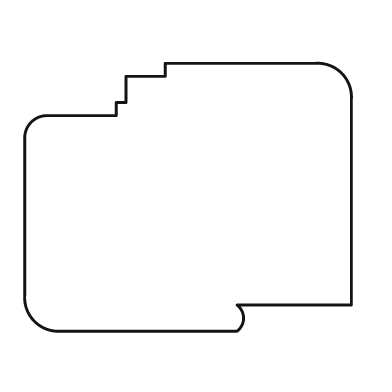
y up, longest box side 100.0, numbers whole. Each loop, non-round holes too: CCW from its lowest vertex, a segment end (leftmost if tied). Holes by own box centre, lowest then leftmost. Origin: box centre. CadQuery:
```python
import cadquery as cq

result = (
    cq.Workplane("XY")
    .moveTo(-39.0, -41.0)
    .lineTo(15.0, -41.0)
    .threePointArc((17.0, -37.0), (15.0, -33.0))
    .lineTo(50.0, -33.0)
    .lineTo(50.0, 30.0)
    .threePointArc((47.0, 38.0), (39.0, 41.0))
    .lineTo(-7.0, 41.0)
    .lineTo(-7.0, 37.0)
    .lineTo(-19.0, 37.0)
    .lineTo(-19.0, 29.0)
    .lineTo(-22.0, 29.0)
    .lineTo(-22.0, 25.0)
    .lineTo(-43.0, 25.0)
    .threePointArc((-48.0, 23.0), (-50.0, 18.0))
    .lineTo(-50.0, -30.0)
    .threePointArc((-47.0, -38.0), (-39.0, -41.0))
    .close()
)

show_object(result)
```